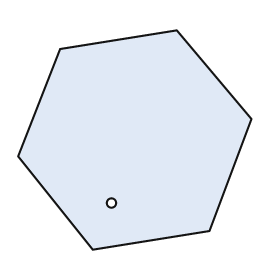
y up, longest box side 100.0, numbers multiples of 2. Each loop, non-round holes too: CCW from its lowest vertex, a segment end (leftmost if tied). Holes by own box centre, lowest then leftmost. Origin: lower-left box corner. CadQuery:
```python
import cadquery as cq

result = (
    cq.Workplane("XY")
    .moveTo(32.0, 0.0)
    .lineTo(82.0, 8.0)
    .lineTo(100.0, 56.0)
    .lineTo(68.0, 94.0)
    .lineTo(18.0, 86.0)
    .lineTo(0.0, 40.0)
    .close()
    .moveTo(40.0, 20.0)
    .circle(2.0)
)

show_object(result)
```